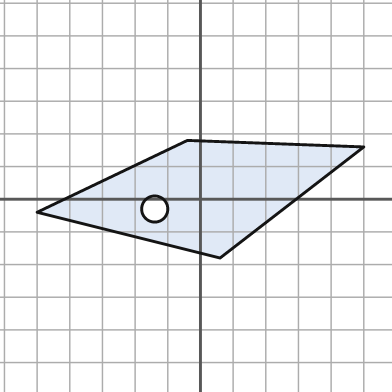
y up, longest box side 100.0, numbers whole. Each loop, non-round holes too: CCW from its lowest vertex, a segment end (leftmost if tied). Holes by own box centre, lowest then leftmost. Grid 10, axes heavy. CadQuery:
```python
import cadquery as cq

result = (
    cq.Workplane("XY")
    .moveTo(6.0, -18.0)
    .lineTo(50.0, 16.0)
    .lineTo(-4.0, 18.0)
    .lineTo(-50.0, -4.0)
    .close()
    .moveTo(-14.0, -3.0)
    .circle(4.0)
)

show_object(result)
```